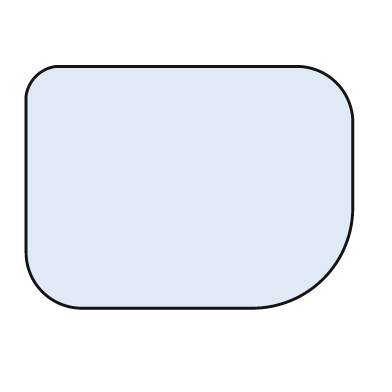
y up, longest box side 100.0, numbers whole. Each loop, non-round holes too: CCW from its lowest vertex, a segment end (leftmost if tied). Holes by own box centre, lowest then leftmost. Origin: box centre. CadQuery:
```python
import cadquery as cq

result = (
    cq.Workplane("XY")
    .moveTo(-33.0, -37.0)
    .lineTo(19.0, -37.0)
    .threePointArc((41.0, -28.0), (50.0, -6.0))
    .lineTo(50.0, 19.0)
    .threePointArc((45.0, 32.0), (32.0, 37.0))
    .lineTo(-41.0, 37.0)
    .threePointArc((-47.0, 34.0), (-50.0, 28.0))
    .lineTo(-50.0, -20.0)
    .threePointArc((-45.0, -32.0), (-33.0, -37.0))
    .close()
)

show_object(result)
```